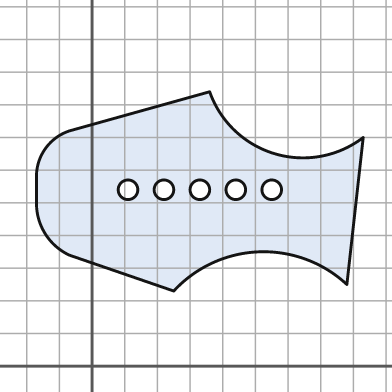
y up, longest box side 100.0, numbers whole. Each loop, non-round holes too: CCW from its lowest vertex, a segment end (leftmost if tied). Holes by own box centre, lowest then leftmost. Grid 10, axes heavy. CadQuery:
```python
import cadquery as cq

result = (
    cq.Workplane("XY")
    .moveTo(25.0, 23.0)
    .threePointArc((51.0, 35.0), (78.0, 25.0))
    .lineTo(83.0, 70.0)
    .threePointArc((56.0, 65.0), (36.0, 84.0))
    .lineTo(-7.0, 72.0)
    .threePointArc((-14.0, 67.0), (-17.0, 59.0))
    .lineTo(-17.0, 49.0)
    .threePointArc((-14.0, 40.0), (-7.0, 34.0))
    .close()
    .moveTo(11.0, 54.0)
    .circle(3.0)
    .moveTo(22.0, 54.0)
    .circle(3.0)
    .moveTo(33.0, 54.0)
    .circle(3.0)
    .moveTo(44.0, 54.0)
    .circle(3.0)
    .moveTo(55.0, 54.0)
    .circle(3.0)
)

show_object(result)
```